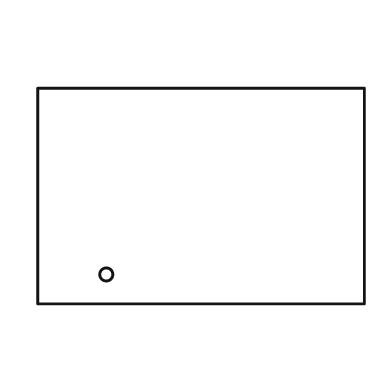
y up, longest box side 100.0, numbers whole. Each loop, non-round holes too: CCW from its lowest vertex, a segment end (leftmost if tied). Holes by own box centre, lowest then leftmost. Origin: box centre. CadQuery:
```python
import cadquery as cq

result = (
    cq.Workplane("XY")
    .moveTo(-50.0, -33.0)
    .lineTo(50.0, -33.0)
    .lineTo(50.0, 33.0)
    .lineTo(-50.0, 33.0)
    .close()
    .moveTo(-29.0, -24.0)
    .circle(2.0)
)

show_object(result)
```